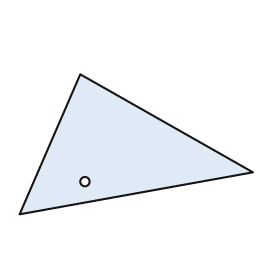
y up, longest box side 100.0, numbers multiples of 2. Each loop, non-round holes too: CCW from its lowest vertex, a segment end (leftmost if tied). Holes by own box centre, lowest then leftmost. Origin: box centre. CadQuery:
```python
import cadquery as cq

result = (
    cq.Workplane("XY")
    .moveTo(-50.0, -30.0)
    .lineTo(50.0, -12.0)
    .lineTo(-24.0, 30.0)
    .close()
    .moveTo(-22.0, -16.0)
    .circle(2.0)
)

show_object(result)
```